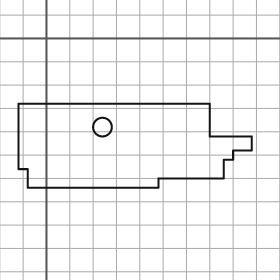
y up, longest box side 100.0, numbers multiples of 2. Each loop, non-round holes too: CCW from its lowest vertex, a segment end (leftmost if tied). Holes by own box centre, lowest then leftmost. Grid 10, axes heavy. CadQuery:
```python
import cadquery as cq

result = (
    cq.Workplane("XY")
    .moveTo(-8.0, -64.0)
    .lineTo(48.0, -64.0)
    .lineTo(48.0, -60.0)
    .lineTo(76.0, -60.0)
    .lineTo(76.0, -52.0)
    .lineTo(80.0, -52.0)
    .lineTo(80.0, -48.0)
    .lineTo(88.0, -48.0)
    .lineTo(88.0, -42.0)
    .lineTo(70.0, -42.0)
    .lineTo(70.0, -28.0)
    .lineTo(-12.0, -28.0)
    .lineTo(-12.0, -56.0)
    .lineTo(-8.0, -56.0)
    .close()
    .moveTo(24.0, -38.0)
    .circle(4.0)
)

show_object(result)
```